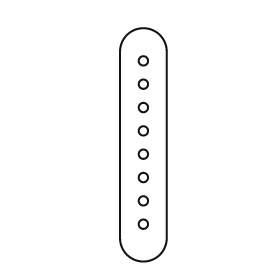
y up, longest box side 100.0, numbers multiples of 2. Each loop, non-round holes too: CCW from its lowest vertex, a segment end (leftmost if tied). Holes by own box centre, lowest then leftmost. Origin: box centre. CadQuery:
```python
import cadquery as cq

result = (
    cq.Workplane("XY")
    .moveTo(-10.0, -40.0)
    .threePointArc((0.0, -50.0), (10.0, -40.0))
    .lineTo(10.0, 40.0)
    .threePointArc((0.0, 50.0), (-10.0, 40.0))
    .close()
    .moveTo(0.0, -34.0)
    .circle(2.0)
    .moveTo(0.0, -24.0)
    .circle(2.0)
    .moveTo(0.0, -14.0)
    .circle(2.0)
    .moveTo(0.0, -4.0)
    .circle(2.0)
    .moveTo(0.0, 6.0)
    .circle(2.0)
    .moveTo(0.0, 16.0)
    .circle(2.0)
    .moveTo(0.0, 26.0)
    .circle(2.0)
    .moveTo(0.0, 36.0)
    .circle(2.0)
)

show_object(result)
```